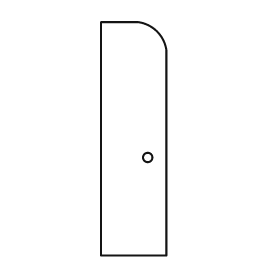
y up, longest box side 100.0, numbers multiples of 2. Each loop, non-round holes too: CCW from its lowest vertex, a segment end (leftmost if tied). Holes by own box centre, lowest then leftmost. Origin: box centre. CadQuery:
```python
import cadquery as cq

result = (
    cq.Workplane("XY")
    .moveTo(-14.0, -50.0)
    .lineTo(14.0, -50.0)
    .lineTo(14.0, 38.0)
    .threePointArc((10.0, 46.0), (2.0, 50.0))
    .lineTo(-14.0, 50.0)
    .close()
    .moveTo(6.0, -8.0)
    .circle(2.0)
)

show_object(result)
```